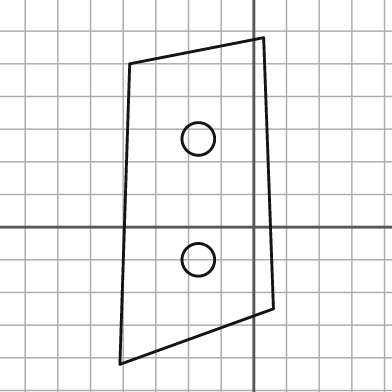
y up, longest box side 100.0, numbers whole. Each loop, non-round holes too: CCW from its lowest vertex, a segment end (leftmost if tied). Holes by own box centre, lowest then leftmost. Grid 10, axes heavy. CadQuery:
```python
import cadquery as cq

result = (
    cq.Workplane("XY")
    .moveTo(-41.0, -42.0)
    .lineTo(6.0, -25.0)
    .lineTo(3.0, 58.0)
    .lineTo(-38.0, 50.0)
    .close()
    .moveTo(-17.0, -10.0)
    .circle(5.0)
    .moveTo(-17.0, 27.0)
    .circle(5.0)
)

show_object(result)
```